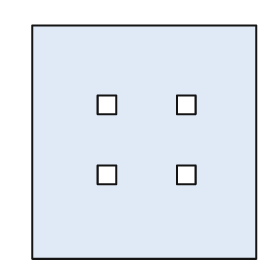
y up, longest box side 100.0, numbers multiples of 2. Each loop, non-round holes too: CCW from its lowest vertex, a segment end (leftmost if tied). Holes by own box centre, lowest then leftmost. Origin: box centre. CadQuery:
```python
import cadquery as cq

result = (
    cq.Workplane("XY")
    .moveTo(-48.0, -50.0)
    .lineTo(48.0, -50.0)
    .lineTo(48.0, 50.0)
    .lineTo(-48.0, 50.0)
    .close()
    .moveTo(-20.0, -18.0)
    .lineTo(-12.0, -18.0)
    .lineTo(-12.0, -10.0)
    .lineTo(-20.0, -10.0)
    .close()
    .moveTo(14.0, -18.0)
    .lineTo(22.0, -18.0)
    .lineTo(22.0, -10.0)
    .lineTo(14.0, -10.0)
    .close()
    .moveTo(-20.0, 12.0)
    .lineTo(-12.0, 12.0)
    .lineTo(-12.0, 20.0)
    .lineTo(-20.0, 20.0)
    .close()
    .moveTo(14.0, 12.0)
    .lineTo(22.0, 12.0)
    .lineTo(22.0, 20.0)
    .lineTo(14.0, 20.0)
    .close()
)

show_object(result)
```